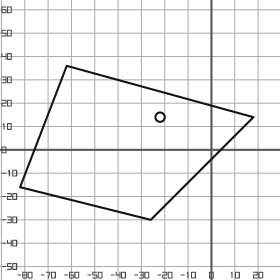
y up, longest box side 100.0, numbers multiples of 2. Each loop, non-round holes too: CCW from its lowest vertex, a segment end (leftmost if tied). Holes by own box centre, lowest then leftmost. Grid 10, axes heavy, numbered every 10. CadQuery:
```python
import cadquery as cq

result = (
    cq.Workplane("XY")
    .moveTo(-26.0, -30.0)
    .lineTo(18.0, 14.0)
    .lineTo(-62.0, 36.0)
    .lineTo(-82.0, -16.0)
    .close()
    .moveTo(-22.0, 14.0)
    .circle(2.0)
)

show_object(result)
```